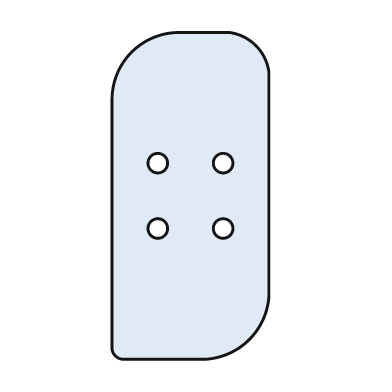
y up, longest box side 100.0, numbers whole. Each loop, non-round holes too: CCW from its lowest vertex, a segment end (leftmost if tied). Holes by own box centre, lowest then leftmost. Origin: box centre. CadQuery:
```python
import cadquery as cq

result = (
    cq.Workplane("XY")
    .moveTo(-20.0, -50.0)
    .lineTo(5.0, -50.0)
    .threePointArc((18.0, -44.0), (24.0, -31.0))
    .lineTo(24.0, 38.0)
    .threePointArc((20.0, 46.0), (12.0, 50.0))
    .lineTo(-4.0, 50.0)
    .threePointArc((-18.0, 44.0), (-24.0, 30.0))
    .lineTo(-24.0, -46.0)
    .threePointArc((-23.0, -49.0), (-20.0, -50.0))
    .close()
    .moveTo(-10.0, -10.0)
    .circle(3.0)
    .moveTo(10.0, -10.0)
    .circle(3.0)
    .moveTo(-10.0, 10.0)
    .circle(3.0)
    .moveTo(10.0, 10.0)
    .circle(3.0)
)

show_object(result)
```